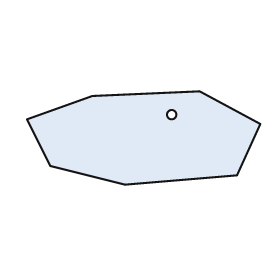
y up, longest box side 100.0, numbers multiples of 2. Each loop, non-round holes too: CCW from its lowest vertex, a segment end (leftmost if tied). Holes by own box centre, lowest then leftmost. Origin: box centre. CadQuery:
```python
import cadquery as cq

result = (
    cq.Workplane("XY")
    .moveTo(-8.0, -20.0)
    .lineTo(40.0, -16.0)
    .lineTo(50.0, 6.0)
    .lineTo(24.0, 20.0)
    .lineTo(-22.0, 18.0)
    .lineTo(-50.0, 8.0)
    .lineTo(-40.0, -12.0)
    .close()
    .moveTo(12.0, 10.0)
    .circle(2.0)
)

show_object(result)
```